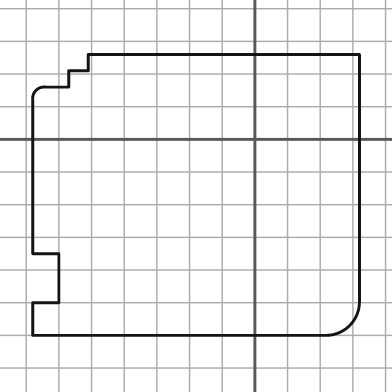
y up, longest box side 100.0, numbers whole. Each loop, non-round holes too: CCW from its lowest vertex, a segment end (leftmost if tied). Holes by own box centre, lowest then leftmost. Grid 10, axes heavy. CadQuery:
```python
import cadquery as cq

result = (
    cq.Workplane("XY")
    .moveTo(-68.0, -60.0)
    .lineTo(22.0, -60.0)
    .threePointArc((29.0, -57.0), (32.0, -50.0))
    .lineTo(32.0, 26.0)
    .lineTo(-51.0, 26.0)
    .lineTo(-51.0, 21.0)
    .lineTo(-57.0, 21.0)
    .lineTo(-57.0, 16.0)
    .lineTo(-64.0, 16.0)
    .threePointArc((-67.0, 15.0), (-68.0, 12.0))
    .lineTo(-68.0, -35.0)
    .lineTo(-60.0, -35.0)
    .lineTo(-60.0, -50.0)
    .lineTo(-68.0, -50.0)
    .close()
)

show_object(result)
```